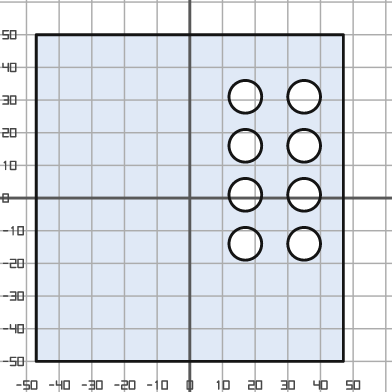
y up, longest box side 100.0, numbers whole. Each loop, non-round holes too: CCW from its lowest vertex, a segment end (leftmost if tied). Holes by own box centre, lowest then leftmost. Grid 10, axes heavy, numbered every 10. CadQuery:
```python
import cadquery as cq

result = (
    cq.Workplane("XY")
    .moveTo(-47.0, -50.0)
    .lineTo(47.0, -50.0)
    .lineTo(47.0, 50.0)
    .lineTo(-47.0, 50.0)
    .close()
    .moveTo(17.0, -14.0)
    .circle(5.0)
    .moveTo(35.0, -14.0)
    .circle(5.0)
    .moveTo(17.0, 1.0)
    .circle(5.0)
    .moveTo(35.0, 1.0)
    .circle(5.0)
    .moveTo(17.0, 16.0)
    .circle(5.0)
    .moveTo(35.0, 16.0)
    .circle(5.0)
    .moveTo(17.0, 31.0)
    .circle(5.0)
    .moveTo(35.0, 31.0)
    .circle(5.0)
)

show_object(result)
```